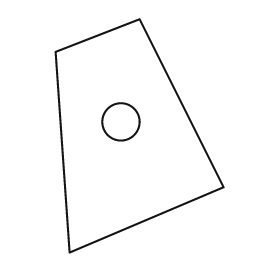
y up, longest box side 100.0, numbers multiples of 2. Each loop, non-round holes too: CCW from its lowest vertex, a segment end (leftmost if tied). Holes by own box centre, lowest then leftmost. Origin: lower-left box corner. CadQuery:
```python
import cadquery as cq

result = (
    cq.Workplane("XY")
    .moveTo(6.0, 0.0)
    .lineTo(72.0, 28.0)
    .lineTo(36.0, 100.0)
    .lineTo(0.0, 86.0)
    .close()
    .moveTo(28.0, 56.0)
    .circle(8.0)
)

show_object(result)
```